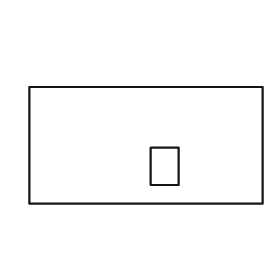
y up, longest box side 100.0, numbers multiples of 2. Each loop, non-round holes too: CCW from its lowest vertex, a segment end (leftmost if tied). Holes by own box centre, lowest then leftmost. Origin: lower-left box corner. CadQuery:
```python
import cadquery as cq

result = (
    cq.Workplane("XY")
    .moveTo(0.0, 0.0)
    .lineTo(100.0, 0.0)
    .lineTo(100.0, 50.0)
    .lineTo(0.0, 50.0)
    .close()
    .moveTo(52.0, 8.0)
    .lineTo(64.0, 8.0)
    .lineTo(64.0, 24.0)
    .lineTo(52.0, 24.0)
    .close()
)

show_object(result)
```